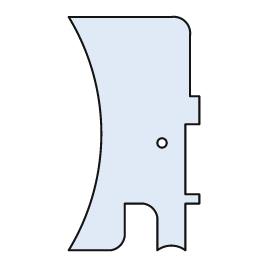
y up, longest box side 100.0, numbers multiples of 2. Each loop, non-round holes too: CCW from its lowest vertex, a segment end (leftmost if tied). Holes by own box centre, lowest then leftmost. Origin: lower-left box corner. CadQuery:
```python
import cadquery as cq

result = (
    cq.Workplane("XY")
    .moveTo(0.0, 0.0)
    .lineTo(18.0, 0.0)
    .threePointArc((22.0, 2.0), (24.0, 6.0))
    .lineTo(24.0, 20.0)
    .lineTo(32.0, 20.0)
    .threePointArc((36.0, 18.0), (38.0, 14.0))
    .lineTo(38.0, 0.0)
    .threePointArc((44.0, 2.0), (50.0, 0.0))
    .lineTo(50.0, 20.0)
    .lineTo(56.0, 20.0)
    .lineTo(56.0, 24.0)
    .lineTo(50.0, 24.0)
    .lineTo(50.0, 54.0)
    .lineTo(56.0, 54.0)
    .lineTo(56.0, 66.0)
    .lineTo(52.0, 66.0)
    .lineTo(52.0, 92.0)
    .threePointArc((50.0, 98.0), (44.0, 100.0))
    .lineTo(0.0, 100.0)
    .threePointArc((14.0, 50.0), (0.0, 0.0))
    .close()
    .moveTo(40.0, 46.0)
    .circle(2.0)
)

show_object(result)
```